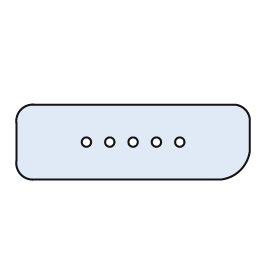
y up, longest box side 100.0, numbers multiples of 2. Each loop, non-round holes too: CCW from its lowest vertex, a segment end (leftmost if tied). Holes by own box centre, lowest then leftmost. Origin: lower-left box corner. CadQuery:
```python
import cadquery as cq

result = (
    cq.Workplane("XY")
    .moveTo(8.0, 0.0)
    .lineTo(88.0, 0.0)
    .threePointArc((96.0, 4.0), (100.0, 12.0))
    .lineTo(100.0, 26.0)
    .threePointArc((98.0, 30.0), (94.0, 32.0))
    .lineTo(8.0, 32.0)
    .threePointArc((2.0, 30.0), (0.0, 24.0))
    .lineTo(0.0, 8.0)
    .threePointArc((2.0, 2.0), (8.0, 0.0))
    .close()
    .moveTo(30.0, 16.0)
    .circle(2.0)
    .moveTo(40.0, 16.0)
    .circle(2.0)
    .moveTo(50.0, 16.0)
    .circle(2.0)
    .moveTo(60.0, 16.0)
    .circle(2.0)
    .moveTo(70.0, 16.0)
    .circle(2.0)
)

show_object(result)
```